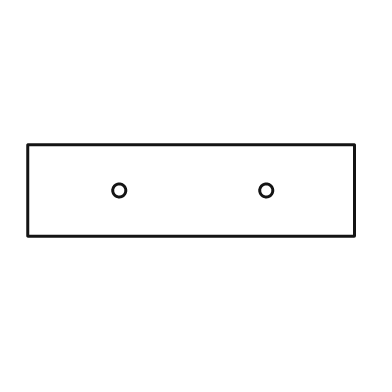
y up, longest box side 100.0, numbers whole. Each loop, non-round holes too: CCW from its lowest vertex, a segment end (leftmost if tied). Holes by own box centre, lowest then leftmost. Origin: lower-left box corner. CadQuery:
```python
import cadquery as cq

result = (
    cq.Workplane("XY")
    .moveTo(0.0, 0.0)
    .lineTo(100.0, 0.0)
    .lineTo(100.0, 28.0)
    .lineTo(0.0, 28.0)
    .close()
    .moveTo(28.0, 14.0)
    .circle(2.0)
    .moveTo(73.0, 14.0)
    .circle(2.0)
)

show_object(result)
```